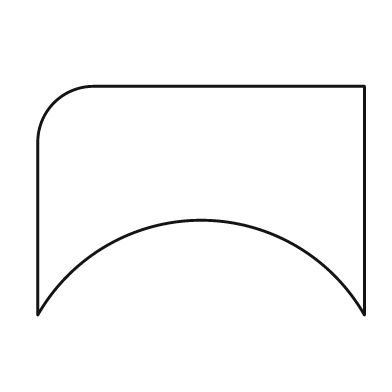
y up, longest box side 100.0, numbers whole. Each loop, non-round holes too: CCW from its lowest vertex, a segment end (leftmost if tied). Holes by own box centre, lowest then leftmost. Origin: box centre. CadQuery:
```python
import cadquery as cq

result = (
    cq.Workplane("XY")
    .moveTo(-50.0, -35.0)
    .threePointArc((0.0, -6.0), (50.0, -35.0))
    .lineTo(50.0, 35.0)
    .lineTo(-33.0, 35.0)
    .threePointArc((-45.0, 30.0), (-50.0, 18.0))
    .close()
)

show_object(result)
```